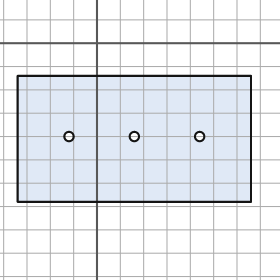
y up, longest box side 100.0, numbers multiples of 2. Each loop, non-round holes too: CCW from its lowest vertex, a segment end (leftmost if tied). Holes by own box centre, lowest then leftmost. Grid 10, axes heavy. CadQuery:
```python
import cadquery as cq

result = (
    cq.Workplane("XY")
    .moveTo(-34.0, -68.0)
    .lineTo(66.0, -68.0)
    .lineTo(66.0, -14.0)
    .lineTo(-34.0, -14.0)
    .close()
    .moveTo(-12.0, -40.0)
    .circle(2.0)
    .moveTo(16.0, -40.0)
    .circle(2.0)
    .moveTo(44.0, -40.0)
    .circle(2.0)
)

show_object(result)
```